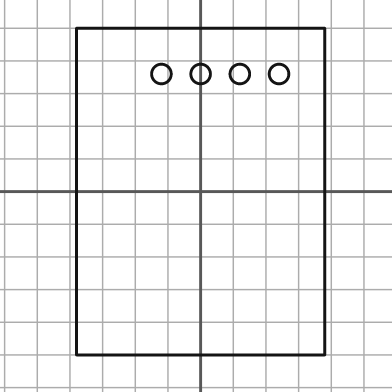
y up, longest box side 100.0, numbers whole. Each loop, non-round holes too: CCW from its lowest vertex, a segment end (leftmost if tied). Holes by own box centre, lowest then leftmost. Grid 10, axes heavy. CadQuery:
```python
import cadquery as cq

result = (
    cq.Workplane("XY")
    .moveTo(-38.0, -50.0)
    .lineTo(38.0, -50.0)
    .lineTo(38.0, 50.0)
    .lineTo(-38.0, 50.0)
    .close()
    .moveTo(-12.0, 36.0)
    .circle(3.0)
    .moveTo(0.0, 36.0)
    .circle(3.0)
    .moveTo(12.0, 36.0)
    .circle(3.0)
    .moveTo(24.0, 36.0)
    .circle(3.0)
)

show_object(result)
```